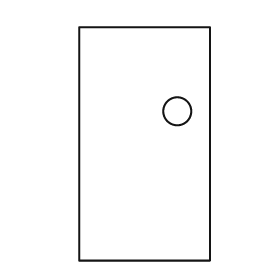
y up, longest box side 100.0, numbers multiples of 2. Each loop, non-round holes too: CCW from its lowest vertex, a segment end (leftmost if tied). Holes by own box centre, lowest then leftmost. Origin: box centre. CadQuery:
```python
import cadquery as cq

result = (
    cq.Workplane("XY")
    .moveTo(-28.0, -50.0)
    .lineTo(28.0, -50.0)
    .lineTo(28.0, 50.0)
    .lineTo(-28.0, 50.0)
    .close()
    .moveTo(14.0, 14.0)
    .circle(6.0)
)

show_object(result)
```